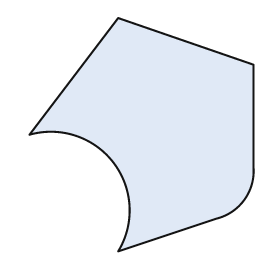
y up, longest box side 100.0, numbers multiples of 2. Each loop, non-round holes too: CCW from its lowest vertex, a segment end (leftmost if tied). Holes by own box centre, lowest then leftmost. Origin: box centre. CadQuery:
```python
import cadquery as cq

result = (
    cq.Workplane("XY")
    .moveTo(-10.0, -50.0)
    .lineTo(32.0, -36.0)
    .threePointArc((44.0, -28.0), (48.0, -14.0))
    .lineTo(48.0, 30.0)
    .lineTo(-10.0, 50.0)
    .lineTo(-48.0, 0.0)
    .threePointArc((-12.0, -12.0), (-10.0, -50.0))
    .close()
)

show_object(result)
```